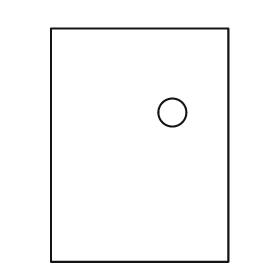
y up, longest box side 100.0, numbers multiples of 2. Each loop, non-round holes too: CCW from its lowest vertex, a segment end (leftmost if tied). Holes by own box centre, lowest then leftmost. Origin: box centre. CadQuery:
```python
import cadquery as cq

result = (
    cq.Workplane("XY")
    .moveTo(-38.0, -50.0)
    .lineTo(38.0, -50.0)
    .lineTo(38.0, 50.0)
    .lineTo(-38.0, 50.0)
    .close()
    .moveTo(14.0, 14.0)
    .circle(6.0)
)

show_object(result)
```